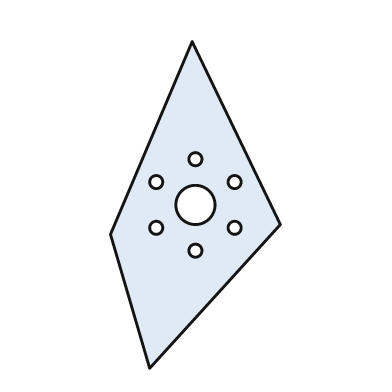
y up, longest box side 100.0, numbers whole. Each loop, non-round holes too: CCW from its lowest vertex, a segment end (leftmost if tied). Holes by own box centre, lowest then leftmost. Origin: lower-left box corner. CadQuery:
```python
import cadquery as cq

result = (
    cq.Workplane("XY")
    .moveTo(12.0, 0.0)
    .lineTo(52.0, 44.0)
    .lineTo(25.0, 100.0)
    .lineTo(0.0, 41.0)
    .close()
    .moveTo(26.0, 36.0)
    .circle(2.0)
    .moveTo(14.0, 43.0)
    .circle(2.0)
    .moveTo(38.0, 43.0)
    .circle(2.0)
    .moveTo(26.0, 50.0)
    .circle(6.0)
    .moveTo(14.0, 57.0)
    .circle(2.0)
    .moveTo(38.0, 57.0)
    .circle(2.0)
    .moveTo(26.0, 64.0)
    .circle(2.0)
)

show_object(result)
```